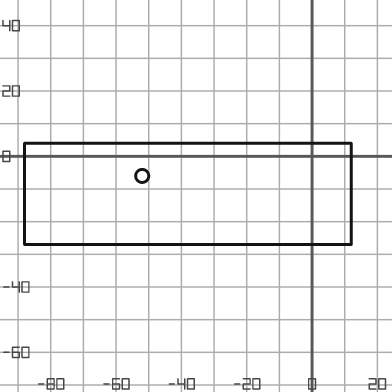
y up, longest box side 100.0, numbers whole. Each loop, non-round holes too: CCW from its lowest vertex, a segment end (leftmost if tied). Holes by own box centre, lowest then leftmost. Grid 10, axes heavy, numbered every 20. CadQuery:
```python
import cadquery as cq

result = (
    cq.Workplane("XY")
    .moveTo(-88.0, -27.0)
    .lineTo(12.0, -27.0)
    .lineTo(12.0, 4.0)
    .lineTo(-88.0, 4.0)
    .close()
    .moveTo(-52.0, -6.0)
    .circle(2.0)
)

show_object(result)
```